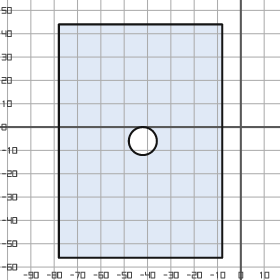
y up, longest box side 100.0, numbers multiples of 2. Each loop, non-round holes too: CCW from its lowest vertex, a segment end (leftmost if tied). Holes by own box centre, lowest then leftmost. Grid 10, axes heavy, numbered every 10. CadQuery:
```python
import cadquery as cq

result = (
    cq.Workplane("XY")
    .moveTo(-78.0, -56.0)
    .lineTo(-8.0, -56.0)
    .lineTo(-8.0, 44.0)
    .lineTo(-78.0, 44.0)
    .close()
    .moveTo(-42.0, -6.0)
    .circle(6.0)
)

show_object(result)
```